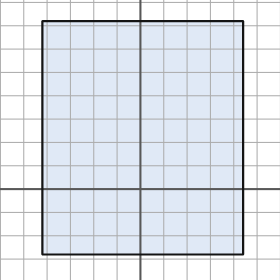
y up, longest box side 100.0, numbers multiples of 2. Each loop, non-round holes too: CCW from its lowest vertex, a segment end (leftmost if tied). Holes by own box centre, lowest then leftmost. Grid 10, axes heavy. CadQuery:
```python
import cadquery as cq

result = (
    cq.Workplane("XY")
    .moveTo(-42.0, -28.0)
    .lineTo(44.0, -28.0)
    .lineTo(44.0, 72.0)
    .lineTo(-42.0, 72.0)
    .close()
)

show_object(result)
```